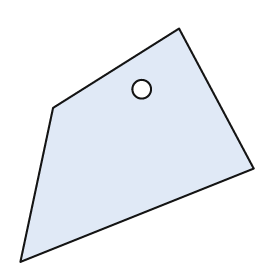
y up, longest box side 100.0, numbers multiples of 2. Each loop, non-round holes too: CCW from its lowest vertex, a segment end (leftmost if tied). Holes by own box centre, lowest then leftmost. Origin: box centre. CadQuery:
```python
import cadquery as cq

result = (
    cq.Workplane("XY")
    .moveTo(-50.0, -50.0)
    .lineTo(50.0, -10.0)
    .lineTo(18.0, 50.0)
    .lineTo(-36.0, 16.0)
    .close()
    .moveTo(2.0, 24.0)
    .circle(4.0)
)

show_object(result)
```